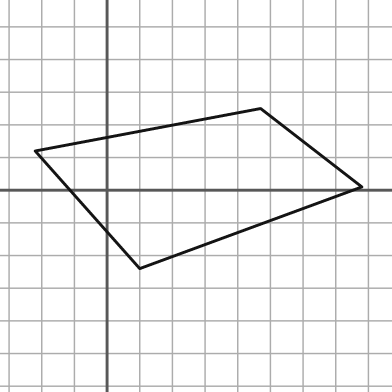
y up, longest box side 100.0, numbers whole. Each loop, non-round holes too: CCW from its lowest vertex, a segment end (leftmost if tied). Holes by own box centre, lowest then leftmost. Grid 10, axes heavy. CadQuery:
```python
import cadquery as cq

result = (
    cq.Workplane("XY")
    .moveTo(10.0, -24.0)
    .lineTo(78.0, 1.0)
    .lineTo(47.0, 25.0)
    .lineTo(-22.0, 12.0)
    .close()
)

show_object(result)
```